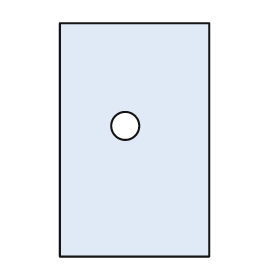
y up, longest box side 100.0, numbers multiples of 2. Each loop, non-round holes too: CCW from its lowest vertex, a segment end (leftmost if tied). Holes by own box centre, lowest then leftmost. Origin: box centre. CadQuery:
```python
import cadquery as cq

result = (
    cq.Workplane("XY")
    .moveTo(-32.0, -50.0)
    .lineTo(32.0, -50.0)
    .lineTo(32.0, 50.0)
    .lineTo(-32.0, 50.0)
    .close()
    .moveTo(-4.0, 6.0)
    .circle(6.0)
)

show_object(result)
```